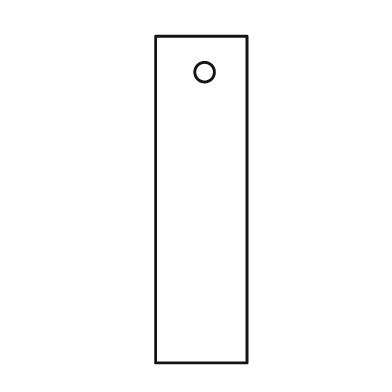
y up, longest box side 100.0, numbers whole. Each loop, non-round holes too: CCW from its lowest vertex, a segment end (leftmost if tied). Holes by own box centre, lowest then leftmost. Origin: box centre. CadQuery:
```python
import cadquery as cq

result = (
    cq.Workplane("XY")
    .moveTo(-14.0, -50.0)
    .lineTo(14.0, -50.0)
    .lineTo(14.0, 50.0)
    .lineTo(-14.0, 50.0)
    .close()
    .moveTo(1.0, 39.0)
    .circle(3.0)
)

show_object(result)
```